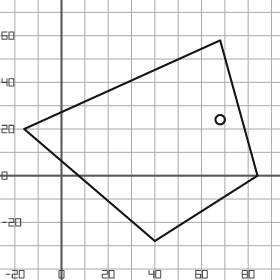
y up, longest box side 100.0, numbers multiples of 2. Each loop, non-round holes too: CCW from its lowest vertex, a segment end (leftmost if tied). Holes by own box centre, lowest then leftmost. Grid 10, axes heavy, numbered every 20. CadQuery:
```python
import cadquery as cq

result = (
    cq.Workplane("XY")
    .moveTo(40.0, -28.0)
    .lineTo(84.0, 0.0)
    .lineTo(68.0, 58.0)
    .lineTo(-16.0, 20.0)
    .close()
    .moveTo(68.0, 24.0)
    .circle(2.0)
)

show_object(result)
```